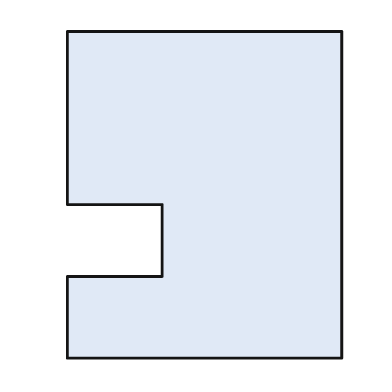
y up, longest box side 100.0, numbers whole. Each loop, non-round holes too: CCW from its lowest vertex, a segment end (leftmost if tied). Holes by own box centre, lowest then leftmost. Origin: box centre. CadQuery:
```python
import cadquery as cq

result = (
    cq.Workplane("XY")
    .moveTo(-42.0, -50.0)
    .lineTo(42.0, -50.0)
    .lineTo(42.0, 50.0)
    .lineTo(-42.0, 50.0)
    .lineTo(-42.0, -3.0)
    .lineTo(-13.0, -3.0)
    .lineTo(-13.0, -25.0)
    .lineTo(-42.0, -25.0)
    .close()
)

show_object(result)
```